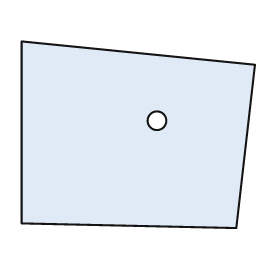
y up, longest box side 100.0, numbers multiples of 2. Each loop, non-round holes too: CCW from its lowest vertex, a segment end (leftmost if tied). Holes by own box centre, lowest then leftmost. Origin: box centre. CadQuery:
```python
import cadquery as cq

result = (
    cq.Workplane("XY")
    .moveTo(42.0, -40.0)
    .lineTo(50.0, 30.0)
    .lineTo(-50.0, 40.0)
    .lineTo(-50.0, -38.0)
    .close()
    .moveTo(8.0, 6.0)
    .circle(4.0)
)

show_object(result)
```